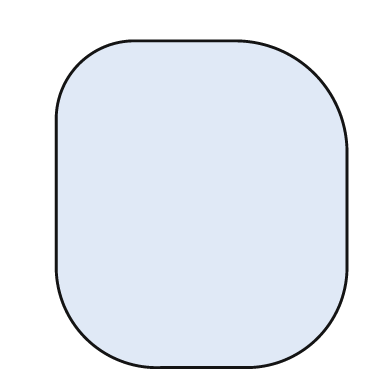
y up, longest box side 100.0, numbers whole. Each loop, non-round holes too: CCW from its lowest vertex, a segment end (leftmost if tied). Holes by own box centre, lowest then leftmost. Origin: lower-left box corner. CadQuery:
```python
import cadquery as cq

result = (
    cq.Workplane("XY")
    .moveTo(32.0, 0.0)
    .lineTo(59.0, 0.0)
    .threePointArc((80.0, 9.0), (89.0, 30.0))
    .lineTo(89.0, 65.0)
    .threePointArc((79.0, 90.0), (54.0, 100.0))
    .lineTo(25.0, 100.0)
    .threePointArc((7.0, 93.0), (0.0, 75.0))
    .lineTo(0.0, 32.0)
    .threePointArc((9.0, 9.0), (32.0, 0.0))
    .close()
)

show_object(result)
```